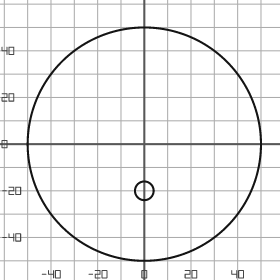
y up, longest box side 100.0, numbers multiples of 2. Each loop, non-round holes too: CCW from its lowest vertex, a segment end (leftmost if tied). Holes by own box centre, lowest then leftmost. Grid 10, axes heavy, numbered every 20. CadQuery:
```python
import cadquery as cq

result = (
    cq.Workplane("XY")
    .moveTo(0.0, 0.0)
    .circle(50.0)
    .moveTo(0.0, -20.0)
    .circle(4.0)
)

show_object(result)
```